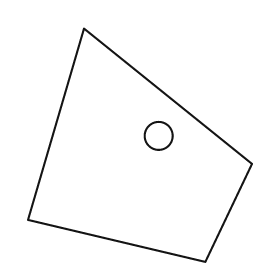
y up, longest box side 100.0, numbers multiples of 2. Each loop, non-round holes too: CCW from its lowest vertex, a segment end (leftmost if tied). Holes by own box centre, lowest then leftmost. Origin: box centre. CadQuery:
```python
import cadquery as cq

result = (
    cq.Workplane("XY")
    .moveTo(28.0, -50.0)
    .lineTo(48.0, -8.0)
    .lineTo(-24.0, 50.0)
    .lineTo(-48.0, -32.0)
    .close()
    .moveTo(8.0, 4.0)
    .circle(6.0)
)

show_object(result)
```